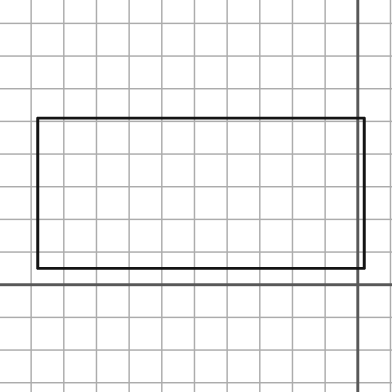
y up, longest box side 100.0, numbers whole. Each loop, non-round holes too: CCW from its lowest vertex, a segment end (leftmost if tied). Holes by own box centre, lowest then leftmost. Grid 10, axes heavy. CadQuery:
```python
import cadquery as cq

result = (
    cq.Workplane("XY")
    .moveTo(-98.0, 5.0)
    .lineTo(2.0, 5.0)
    .lineTo(2.0, 51.0)
    .lineTo(-98.0, 51.0)
    .close()
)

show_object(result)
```